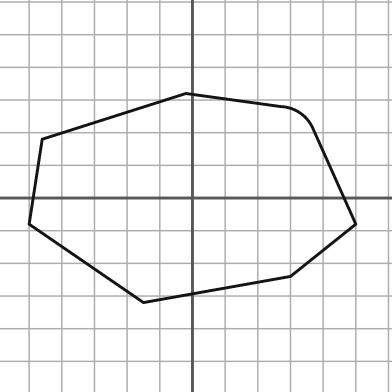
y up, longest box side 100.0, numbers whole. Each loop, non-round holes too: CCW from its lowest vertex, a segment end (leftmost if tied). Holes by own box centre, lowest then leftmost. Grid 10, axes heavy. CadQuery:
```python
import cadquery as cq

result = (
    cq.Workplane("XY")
    .moveTo(-15.0, -32.0)
    .lineTo(30.0, -24.0)
    .lineTo(50.0, -8.0)
    .lineTo(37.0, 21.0)
    .threePointArc((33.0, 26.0), (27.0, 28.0))
    .lineTo(-2.0, 32.0)
    .lineTo(-46.0, 18.0)
    .lineTo(-50.0, -8.0)
    .close()
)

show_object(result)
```